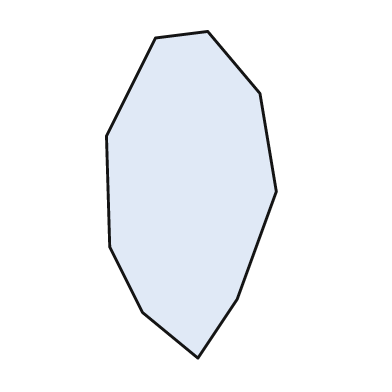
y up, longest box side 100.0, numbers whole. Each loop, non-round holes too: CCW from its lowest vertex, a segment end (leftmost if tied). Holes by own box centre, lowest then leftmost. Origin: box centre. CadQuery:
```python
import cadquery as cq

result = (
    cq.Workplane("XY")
    .moveTo(2.0, -50.0)
    .lineTo(14.0, -32.0)
    .lineTo(26.0, 1.0)
    .lineTo(21.0, 31.0)
    .lineTo(5.0, 50.0)
    .lineTo(-11.0, 48.0)
    .lineTo(-26.0, 18.0)
    .lineTo(-25.0, -16.0)
    .lineTo(-15.0, -36.0)
    .close()
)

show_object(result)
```